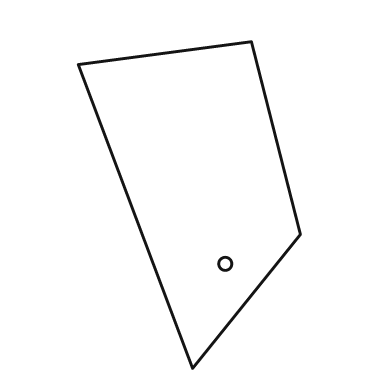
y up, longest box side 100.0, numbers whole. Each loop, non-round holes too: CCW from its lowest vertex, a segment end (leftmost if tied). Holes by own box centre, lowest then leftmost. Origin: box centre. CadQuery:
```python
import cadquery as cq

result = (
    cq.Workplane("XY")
    .moveTo(1.0, -50.0)
    .lineTo(34.0, -9.0)
    .lineTo(19.0, 50.0)
    .lineTo(-34.0, 43.0)
    .close()
    .moveTo(11.0, -18.0)
    .circle(2.0)
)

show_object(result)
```